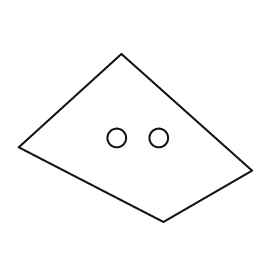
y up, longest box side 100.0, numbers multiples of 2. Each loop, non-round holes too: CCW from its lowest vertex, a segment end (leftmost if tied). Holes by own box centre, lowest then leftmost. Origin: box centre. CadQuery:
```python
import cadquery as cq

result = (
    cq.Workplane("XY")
    .moveTo(12.0, -36.0)
    .lineTo(50.0, -14.0)
    .lineTo(-6.0, 36.0)
    .lineTo(-50.0, -4.0)
    .close()
    .moveTo(-8.0, 0.0)
    .circle(4.0)
    .moveTo(10.0, 0.0)
    .circle(4.0)
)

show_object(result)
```